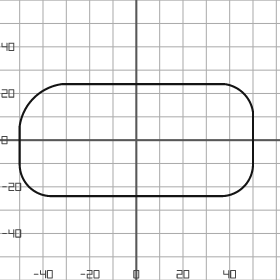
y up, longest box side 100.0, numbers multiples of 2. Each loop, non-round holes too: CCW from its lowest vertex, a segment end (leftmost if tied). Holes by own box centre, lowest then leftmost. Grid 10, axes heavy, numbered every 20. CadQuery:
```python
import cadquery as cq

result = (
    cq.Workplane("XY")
    .moveTo(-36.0, -24.0)
    .lineTo(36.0, -24.0)
    .threePointArc((46.0, -20.0), (50.0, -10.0))
    .lineTo(50.0, 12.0)
    .threePointArc((46.0, 20.0), (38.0, 24.0))
    .lineTo(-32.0, 24.0)
    .threePointArc((-44.0, 18.0), (-50.0, 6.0))
    .lineTo(-50.0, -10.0)
    .threePointArc((-46.0, -20.0), (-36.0, -24.0))
    .close()
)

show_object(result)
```